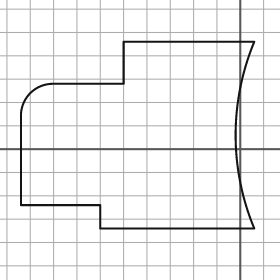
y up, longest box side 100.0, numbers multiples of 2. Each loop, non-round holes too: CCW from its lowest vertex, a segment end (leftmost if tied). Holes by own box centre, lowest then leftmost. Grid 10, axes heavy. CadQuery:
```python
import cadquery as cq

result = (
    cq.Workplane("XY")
    .moveTo(-60.0, -34.0)
    .lineTo(6.0, -34.0)
    .threePointArc((-2.0, 6.0), (6.0, 46.0))
    .lineTo(-50.0, 46.0)
    .lineTo(-50.0, 28.0)
    .lineTo(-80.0, 28.0)
    .threePointArc((-90.0, 24.0), (-94.0, 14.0))
    .lineTo(-94.0, -24.0)
    .lineTo(-60.0, -24.0)
    .close()
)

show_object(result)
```